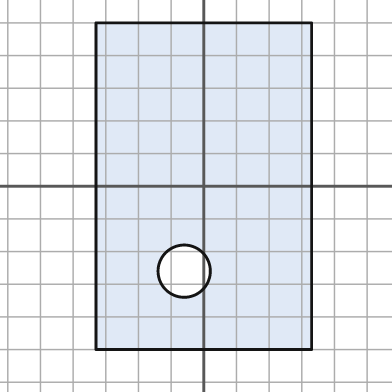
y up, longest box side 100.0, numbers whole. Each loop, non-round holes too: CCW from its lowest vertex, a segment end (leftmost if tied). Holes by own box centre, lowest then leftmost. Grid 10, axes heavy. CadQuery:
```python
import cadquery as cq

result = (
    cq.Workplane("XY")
    .moveTo(-33.0, -50.0)
    .lineTo(33.0, -50.0)
    .lineTo(33.0, 50.0)
    .lineTo(-33.0, 50.0)
    .close()
    .moveTo(-6.0, -26.0)
    .circle(8.0)
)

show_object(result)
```